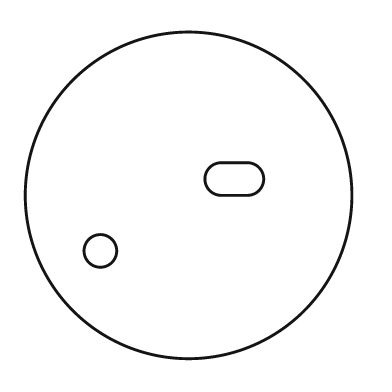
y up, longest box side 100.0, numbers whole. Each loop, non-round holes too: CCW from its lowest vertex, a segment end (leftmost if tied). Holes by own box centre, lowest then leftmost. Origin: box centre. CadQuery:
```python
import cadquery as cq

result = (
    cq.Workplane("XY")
    .moveTo(0.0, 0.0)
    .circle(50.0)
    .moveTo(-27.0, -17.0)
    .circle(5.0)
    .moveTo(10.0, 0.0)
    .lineTo(18.0, 0.0)
    .threePointArc((23.0, 5.0), (18.0, 10.0))
    .lineTo(10.0, 10.0)
    .threePointArc((5.0, 5.0), (10.0, 0.0))
    .close()
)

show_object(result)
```